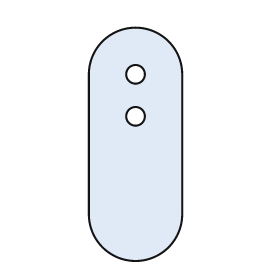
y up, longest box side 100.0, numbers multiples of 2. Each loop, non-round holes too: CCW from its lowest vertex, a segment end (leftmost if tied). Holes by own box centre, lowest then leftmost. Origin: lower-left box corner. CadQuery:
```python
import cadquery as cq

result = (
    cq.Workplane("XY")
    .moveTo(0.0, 20.0)
    .threePointArc((20.0, 0.0), (40.0, 20.0))
    .lineTo(40.0, 80.0)
    .threePointArc((20.0, 100.0), (0.0, 80.0))
    .close()
    .moveTo(20.0, 62.0)
    .circle(4.0)
    .moveTo(20.0, 80.0)
    .circle(4.0)
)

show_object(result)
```